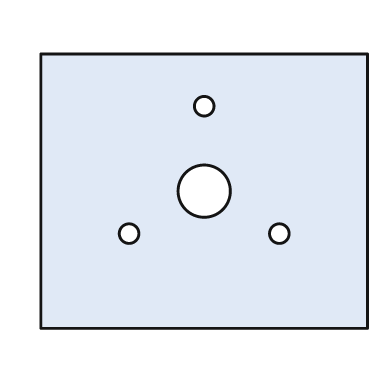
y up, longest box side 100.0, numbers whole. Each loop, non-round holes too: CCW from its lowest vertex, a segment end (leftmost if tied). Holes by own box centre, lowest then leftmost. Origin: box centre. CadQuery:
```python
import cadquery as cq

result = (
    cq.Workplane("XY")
    .moveTo(-50.0, -42.0)
    .lineTo(50.0, -42.0)
    .lineTo(50.0, 42.0)
    .lineTo(-50.0, 42.0)
    .close()
    .moveTo(-23.0, -13.0)
    .circle(3.0)
    .moveTo(23.0, -13.0)
    .circle(3.0)
    .moveTo(0.0, 0.0)
    .circle(8.0)
    .moveTo(0.0, 26.0)
    .circle(3.0)
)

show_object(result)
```